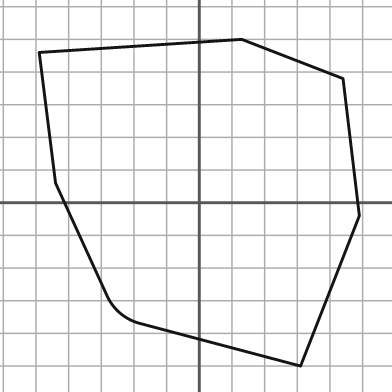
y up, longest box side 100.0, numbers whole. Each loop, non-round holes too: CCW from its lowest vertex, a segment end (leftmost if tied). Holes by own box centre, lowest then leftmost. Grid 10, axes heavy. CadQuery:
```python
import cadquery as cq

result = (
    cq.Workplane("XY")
    .moveTo(31.0, -50.0)
    .lineTo(49.0, -4.0)
    .lineTo(44.0, 38.0)
    .lineTo(13.0, 50.0)
    .lineTo(-49.0, 46.0)
    .lineTo(-44.0, 6.0)
    .lineTo(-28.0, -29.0)
    .threePointArc((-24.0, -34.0), (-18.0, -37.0))
    .close()
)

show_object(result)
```